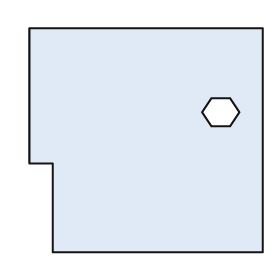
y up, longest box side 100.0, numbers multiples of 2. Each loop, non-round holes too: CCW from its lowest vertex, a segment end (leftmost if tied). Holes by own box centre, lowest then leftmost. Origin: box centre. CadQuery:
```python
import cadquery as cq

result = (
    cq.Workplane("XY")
    .moveTo(-40.0, -48.0)
    .lineTo(50.0, -48.0)
    .lineTo(50.0, 48.0)
    .lineTo(-50.0, 48.0)
    .lineTo(-50.0, -10.0)
    .lineTo(-40.0, -10.0)
    .close()
    .moveTo(28.0, 6.0)
    .lineTo(36.0, 6.0)
    .lineTo(40.0, 12.0)
    .lineTo(36.0, 18.0)
    .lineTo(28.0, 18.0)
    .lineTo(24.0, 12.0)
    .close()
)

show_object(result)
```